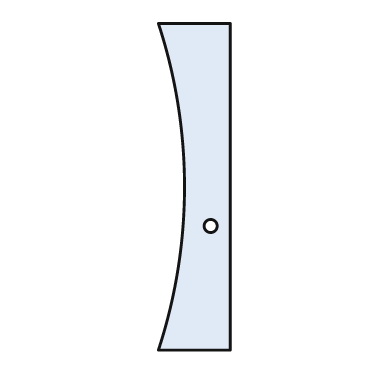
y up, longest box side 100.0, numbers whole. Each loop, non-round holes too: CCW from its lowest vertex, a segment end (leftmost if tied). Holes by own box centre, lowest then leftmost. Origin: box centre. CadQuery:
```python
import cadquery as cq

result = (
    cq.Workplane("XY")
    .moveTo(-11.0, -50.0)
    .lineTo(11.0, -50.0)
    .lineTo(11.0, 50.0)
    .lineTo(-11.0, 50.0)
    .threePointArc((-3.0, 0.0), (-11.0, -50.0))
    .close()
    .moveTo(5.0, -12.0)
    .circle(2.0)
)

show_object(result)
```